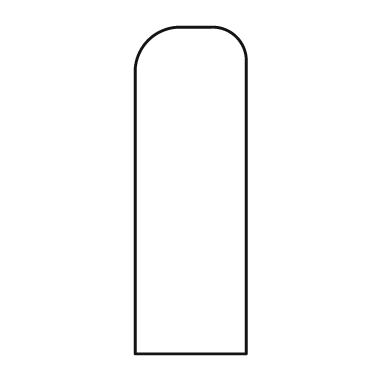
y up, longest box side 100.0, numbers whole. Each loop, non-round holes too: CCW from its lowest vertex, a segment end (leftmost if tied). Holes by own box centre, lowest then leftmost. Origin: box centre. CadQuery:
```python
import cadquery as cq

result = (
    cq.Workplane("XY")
    .moveTo(-17.0, -50.0)
    .lineTo(17.0, -50.0)
    .lineTo(17.0, 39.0)
    .threePointArc((14.0, 47.0), (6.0, 50.0))
    .lineTo(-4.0, 50.0)
    .threePointArc((-13.0, 46.0), (-17.0, 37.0))
    .close()
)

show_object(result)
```